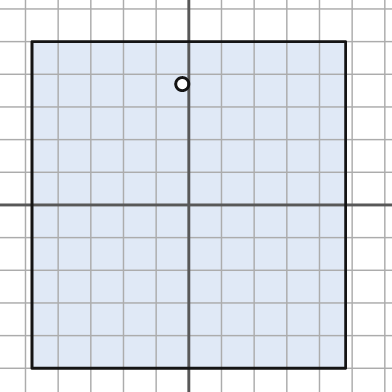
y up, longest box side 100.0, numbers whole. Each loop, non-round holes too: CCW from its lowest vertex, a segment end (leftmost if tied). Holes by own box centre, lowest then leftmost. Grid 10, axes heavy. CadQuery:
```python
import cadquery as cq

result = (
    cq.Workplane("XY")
    .moveTo(-48.0, -50.0)
    .lineTo(48.0, -50.0)
    .lineTo(48.0, 50.0)
    .lineTo(-48.0, 50.0)
    .close()
    .moveTo(-2.0, 37.0)
    .circle(2.0)
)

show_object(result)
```